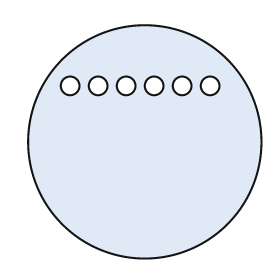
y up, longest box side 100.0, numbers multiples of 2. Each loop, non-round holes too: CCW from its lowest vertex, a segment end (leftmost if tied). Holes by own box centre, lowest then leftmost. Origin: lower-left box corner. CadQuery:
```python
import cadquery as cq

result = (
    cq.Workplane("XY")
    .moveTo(50.0, 50.0)
    .circle(50.0)
    .moveTo(18.0, 74.0)
    .circle(4.0)
    .moveTo(30.0, 74.0)
    .circle(4.0)
    .moveTo(42.0, 74.0)
    .circle(4.0)
    .moveTo(54.0, 74.0)
    .circle(4.0)
    .moveTo(66.0, 74.0)
    .circle(4.0)
    .moveTo(78.0, 74.0)
    .circle(4.0)
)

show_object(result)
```